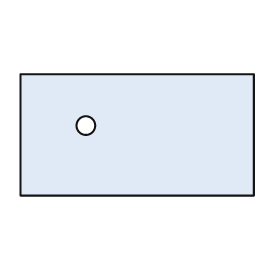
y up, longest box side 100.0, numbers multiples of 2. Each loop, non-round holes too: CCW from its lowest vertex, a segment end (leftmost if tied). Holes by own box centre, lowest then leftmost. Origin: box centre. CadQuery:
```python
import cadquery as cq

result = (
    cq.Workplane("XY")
    .moveTo(-50.0, -26.0)
    .lineTo(50.0, -26.0)
    .lineTo(50.0, 26.0)
    .lineTo(-50.0, 26.0)
    .close()
    .moveTo(-22.0, 4.0)
    .circle(4.0)
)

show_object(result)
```